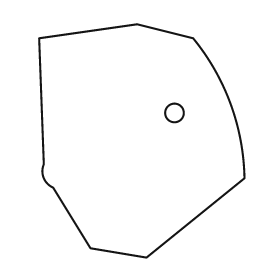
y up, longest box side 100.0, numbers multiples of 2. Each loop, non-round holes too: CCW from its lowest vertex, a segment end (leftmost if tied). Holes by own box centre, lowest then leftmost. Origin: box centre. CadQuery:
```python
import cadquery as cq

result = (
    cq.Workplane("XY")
    .moveTo(2.0, -50.0)
    .lineTo(44.0, -16.0)
    .threePointArc((38.0, 16.0), (22.0, 44.0))
    .lineTo(-2.0, 50.0)
    .lineTo(-44.0, 44.0)
    .lineTo(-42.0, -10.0)
    .threePointArc((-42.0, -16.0), (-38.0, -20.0))
    .lineTo(-22.0, -46.0)
    .close()
    .moveTo(14.0, 12.0)
    .circle(4.0)
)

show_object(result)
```